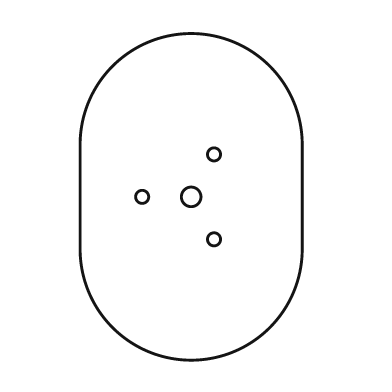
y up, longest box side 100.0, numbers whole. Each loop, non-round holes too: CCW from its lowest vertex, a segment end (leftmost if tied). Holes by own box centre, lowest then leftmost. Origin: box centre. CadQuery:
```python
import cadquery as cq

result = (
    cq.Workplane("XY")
    .moveTo(-34.0, -16.0)
    .threePointArc((0.0, -50.0), (34.0, -16.0))
    .lineTo(34.0, 16.0)
    .threePointArc((0.0, 50.0), (-34.0, 16.0))
    .close()
    .moveTo(7.0, -13.0)
    .circle(2.0)
    .moveTo(-15.0, 0.0)
    .circle(2.0)
    .moveTo(0.0, 0.0)
    .circle(3.0)
    .moveTo(7.0, 13.0)
    .circle(2.0)
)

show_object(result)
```